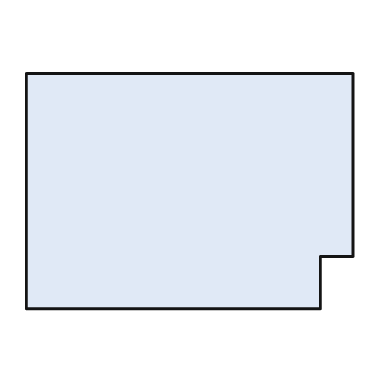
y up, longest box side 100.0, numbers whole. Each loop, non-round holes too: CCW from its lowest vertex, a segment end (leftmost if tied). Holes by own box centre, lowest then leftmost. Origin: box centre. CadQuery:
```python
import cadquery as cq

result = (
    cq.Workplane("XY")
    .moveTo(-50.0, -36.0)
    .lineTo(40.0, -36.0)
    .lineTo(40.0, -20.0)
    .lineTo(50.0, -20.0)
    .lineTo(50.0, 36.0)
    .lineTo(-50.0, 36.0)
    .close()
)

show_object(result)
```